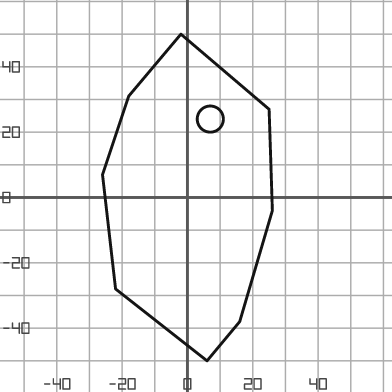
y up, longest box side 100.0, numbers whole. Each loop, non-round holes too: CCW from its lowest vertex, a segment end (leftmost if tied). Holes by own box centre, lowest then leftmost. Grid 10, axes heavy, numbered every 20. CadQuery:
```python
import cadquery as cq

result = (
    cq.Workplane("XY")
    .moveTo(6.0, -50.0)
    .lineTo(16.0, -38.0)
    .lineTo(26.0, -4.0)
    .lineTo(25.0, 27.0)
    .lineTo(-2.0, 50.0)
    .lineTo(-18.0, 31.0)
    .lineTo(-26.0, 7.0)
    .lineTo(-22.0, -28.0)
    .close()
    .moveTo(7.0, 24.0)
    .circle(4.0)
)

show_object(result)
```